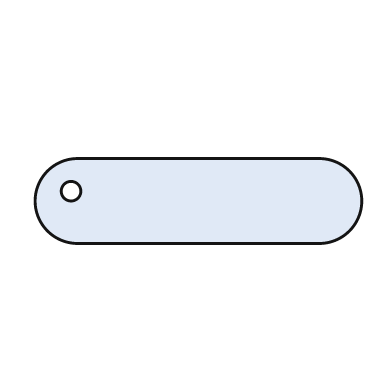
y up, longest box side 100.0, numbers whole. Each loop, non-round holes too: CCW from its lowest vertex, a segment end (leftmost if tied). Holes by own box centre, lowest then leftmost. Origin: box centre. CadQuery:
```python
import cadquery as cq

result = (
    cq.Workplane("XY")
    .moveTo(-37.0, -13.0)
    .lineTo(37.0, -13.0)
    .threePointArc((50.0, 0.0), (37.0, 13.0))
    .lineTo(-37.0, 13.0)
    .threePointArc((-50.0, 0.0), (-37.0, -13.0))
    .close()
    .moveTo(-39.0, 3.0)
    .circle(3.0)
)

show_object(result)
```